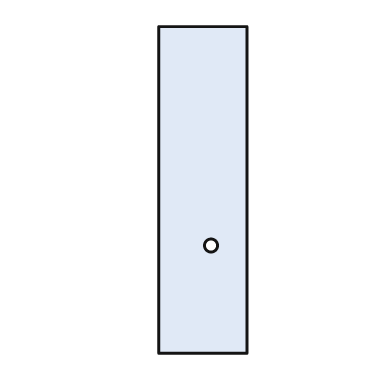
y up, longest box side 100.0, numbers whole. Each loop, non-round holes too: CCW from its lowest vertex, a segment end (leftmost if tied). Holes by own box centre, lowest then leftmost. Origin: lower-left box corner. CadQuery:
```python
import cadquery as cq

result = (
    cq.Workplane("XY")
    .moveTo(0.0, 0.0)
    .lineTo(27.0, 0.0)
    .lineTo(27.0, 100.0)
    .lineTo(0.0, 100.0)
    .close()
    .moveTo(16.0, 33.0)
    .circle(2.0)
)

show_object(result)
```